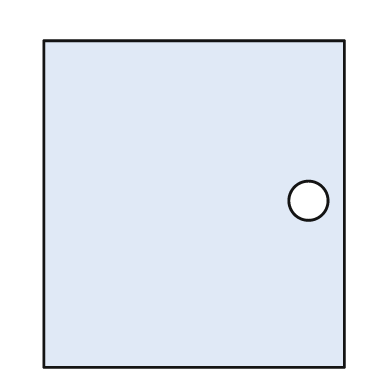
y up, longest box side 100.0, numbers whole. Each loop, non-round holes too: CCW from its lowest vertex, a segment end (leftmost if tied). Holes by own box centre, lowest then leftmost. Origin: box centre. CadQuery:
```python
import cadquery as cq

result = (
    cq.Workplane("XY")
    .moveTo(-46.0, -50.0)
    .lineTo(46.0, -50.0)
    .lineTo(46.0, 50.0)
    .lineTo(-46.0, 50.0)
    .close()
    .moveTo(35.0, 1.0)
    .circle(6.0)
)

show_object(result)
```